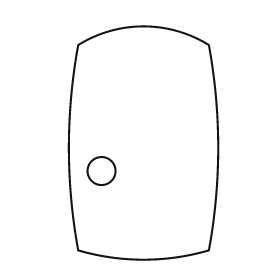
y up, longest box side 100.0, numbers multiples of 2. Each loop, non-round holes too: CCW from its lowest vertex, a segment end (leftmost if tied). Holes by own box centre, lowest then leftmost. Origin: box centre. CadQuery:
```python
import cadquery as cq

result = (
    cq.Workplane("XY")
    .moveTo(-28.0, -46.0)
    .threePointArc((0.0, -50.0), (28.0, -46.0))
    .threePointArc((32.0, -2.0), (28.0, 42.0))
    .threePointArc((0.0, 50.0), (-28.0, 42.0))
    .threePointArc((-32.0, -2.0), (-28.0, -46.0))
    .close()
    .moveTo(-18.0, -12.0)
    .circle(6.0)
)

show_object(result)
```